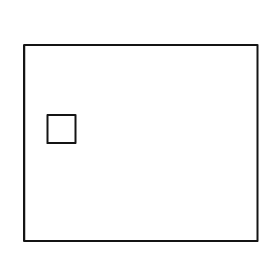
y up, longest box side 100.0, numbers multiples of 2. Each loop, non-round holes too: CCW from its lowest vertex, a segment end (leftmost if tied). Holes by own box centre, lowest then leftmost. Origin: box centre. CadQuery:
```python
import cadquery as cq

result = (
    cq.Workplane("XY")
    .moveTo(-50.0, -42.0)
    .lineTo(50.0, -42.0)
    .lineTo(50.0, 42.0)
    .lineTo(-50.0, 42.0)
    .close()
    .moveTo(-40.0, 0.0)
    .lineTo(-28.0, 0.0)
    .lineTo(-28.0, 12.0)
    .lineTo(-40.0, 12.0)
    .close()
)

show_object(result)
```